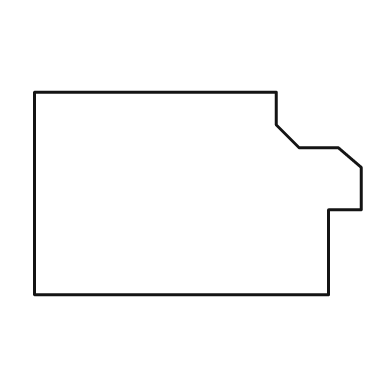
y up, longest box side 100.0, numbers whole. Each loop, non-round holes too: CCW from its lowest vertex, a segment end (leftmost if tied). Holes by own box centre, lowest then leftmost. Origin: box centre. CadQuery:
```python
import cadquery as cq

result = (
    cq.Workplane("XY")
    .moveTo(-50.0, -31.0)
    .lineTo(40.0, -31.0)
    .lineTo(40.0, -5.0)
    .lineTo(50.0, -5.0)
    .lineTo(50.0, 8.0)
    .lineTo(43.0, 14.0)
    .lineTo(31.0, 14.0)
    .lineTo(24.0, 21.0)
    .lineTo(24.0, 31.0)
    .lineTo(-50.0, 31.0)
    .close()
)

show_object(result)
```